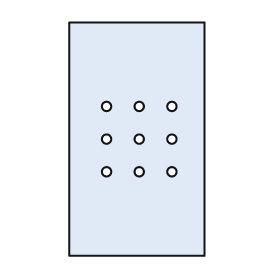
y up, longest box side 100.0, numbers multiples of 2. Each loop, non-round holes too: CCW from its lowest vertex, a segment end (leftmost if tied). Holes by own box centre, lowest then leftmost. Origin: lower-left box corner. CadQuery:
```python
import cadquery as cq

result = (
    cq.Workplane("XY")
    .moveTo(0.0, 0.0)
    .lineTo(58.0, 0.0)
    .lineTo(58.0, 100.0)
    .lineTo(0.0, 100.0)
    .close()
    .moveTo(16.0, 36.0)
    .circle(2.0)
    .moveTo(30.0, 36.0)
    .circle(2.0)
    .moveTo(44.0, 36.0)
    .circle(2.0)
    .moveTo(16.0, 50.0)
    .circle(2.0)
    .moveTo(30.0, 50.0)
    .circle(2.0)
    .moveTo(44.0, 50.0)
    .circle(2.0)
    .moveTo(16.0, 64.0)
    .circle(2.0)
    .moveTo(30.0, 64.0)
    .circle(2.0)
    .moveTo(44.0, 64.0)
    .circle(2.0)
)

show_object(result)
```